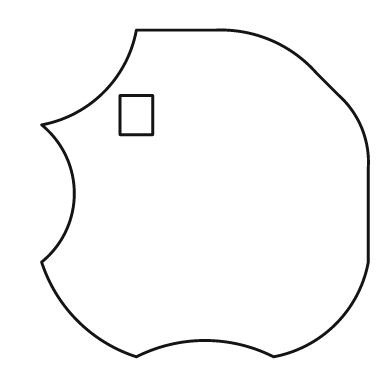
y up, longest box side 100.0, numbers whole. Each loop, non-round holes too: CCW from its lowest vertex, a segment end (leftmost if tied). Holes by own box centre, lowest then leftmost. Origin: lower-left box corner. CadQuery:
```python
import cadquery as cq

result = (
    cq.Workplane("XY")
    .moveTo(29.0, 0.0)
    .threePointArc((50.0, 5.0), (71.0, 0.0))
    .threePointArc((90.0, 10.0), (100.0, 29.0))
    .lineTo(100.0, 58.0)
    .threePointArc((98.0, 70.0), (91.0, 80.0))
    .lineTo(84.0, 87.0)
    .threePointArc((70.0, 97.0), (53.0, 100.0))
    .lineTo(29.0, 100.0)
    .threePointArc((19.0, 81.0), (0.0, 71.0))
    .threePointArc((10.0, 50.0), (0.0, 29.0))
    .threePointArc((11.0, 11.0), (29.0, 0.0))
    .close()
    .moveTo(24.0, 68.0)
    .lineTo(34.0, 68.0)
    .lineTo(34.0, 80.0)
    .lineTo(24.0, 80.0)
    .close()
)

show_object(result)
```